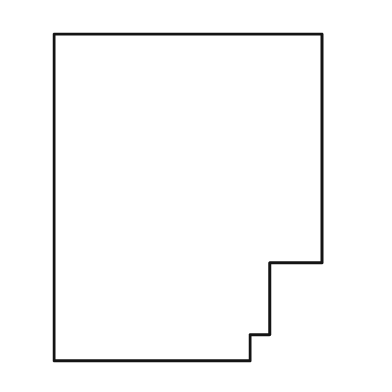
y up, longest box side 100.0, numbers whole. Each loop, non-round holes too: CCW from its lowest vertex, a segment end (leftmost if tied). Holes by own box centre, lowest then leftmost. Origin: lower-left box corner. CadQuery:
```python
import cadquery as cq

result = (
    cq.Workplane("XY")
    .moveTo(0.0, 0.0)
    .lineTo(60.0, 0.0)
    .lineTo(60.0, 8.0)
    .lineTo(66.0, 8.0)
    .lineTo(66.0, 30.0)
    .lineTo(82.0, 30.0)
    .lineTo(82.0, 100.0)
    .lineTo(0.0, 100.0)
    .close()
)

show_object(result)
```